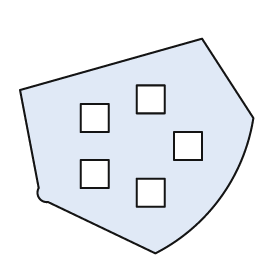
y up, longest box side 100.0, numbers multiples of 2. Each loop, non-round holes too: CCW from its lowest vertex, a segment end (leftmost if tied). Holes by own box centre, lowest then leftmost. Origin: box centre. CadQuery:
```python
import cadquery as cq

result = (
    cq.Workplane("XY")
    .moveTo(8.0, -46.0)
    .threePointArc((36.0, -22.0), (50.0, 12.0))
    .lineTo(28.0, 46.0)
    .lineTo(-50.0, 24.0)
    .lineTo(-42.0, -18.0)
    .threePointArc((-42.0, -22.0), (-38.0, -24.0))
    .close()
    .moveTo(0.0, -26.0)
    .lineTo(12.0, -26.0)
    .lineTo(12.0, -14.0)
    .lineTo(0.0, -14.0)
    .close()
    .moveTo(-24.0, -18.0)
    .lineTo(-12.0, -18.0)
    .lineTo(-12.0, -6.0)
    .lineTo(-24.0, -6.0)
    .close()
    .moveTo(16.0, -6.0)
    .lineTo(28.0, -6.0)
    .lineTo(28.0, 6.0)
    .lineTo(16.0, 6.0)
    .close()
    .moveTo(-24.0, 6.0)
    .lineTo(-12.0, 6.0)
    .lineTo(-12.0, 18.0)
    .lineTo(-24.0, 18.0)
    .close()
    .moveTo(0.0, 14.0)
    .lineTo(12.0, 14.0)
    .lineTo(12.0, 26.0)
    .lineTo(0.0, 26.0)
    .close()
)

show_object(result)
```